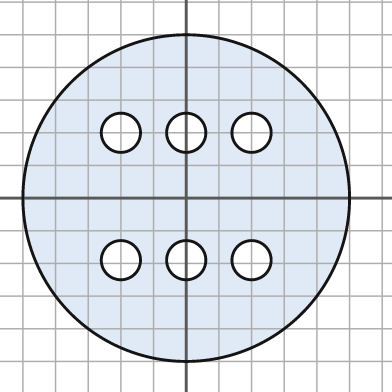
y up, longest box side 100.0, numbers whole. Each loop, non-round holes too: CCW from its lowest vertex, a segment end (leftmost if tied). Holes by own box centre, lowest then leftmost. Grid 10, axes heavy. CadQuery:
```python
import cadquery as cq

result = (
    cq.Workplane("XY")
    .moveTo(0.0, 0.0)
    .circle(50.0)
    .moveTo(-20.0, -19.0)
    .circle(6.0)
    .moveTo(0.0, -19.0)
    .circle(6.0)
    .moveTo(20.0, -19.0)
    .circle(6.0)
    .moveTo(-20.0, 20.0)
    .circle(6.0)
    .moveTo(0.0, 20.0)
    .circle(6.0)
    .moveTo(20.0, 20.0)
    .circle(6.0)
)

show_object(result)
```